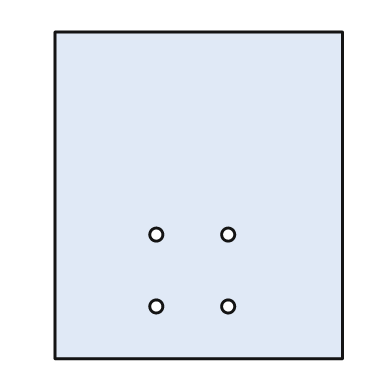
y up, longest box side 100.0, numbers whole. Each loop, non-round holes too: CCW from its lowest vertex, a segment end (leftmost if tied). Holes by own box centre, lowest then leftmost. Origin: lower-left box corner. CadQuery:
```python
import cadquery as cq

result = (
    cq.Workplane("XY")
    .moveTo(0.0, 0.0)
    .lineTo(88.0, 0.0)
    .lineTo(88.0, 100.0)
    .lineTo(0.0, 100.0)
    .close()
    .moveTo(31.0, 16.0)
    .circle(2.0)
    .moveTo(53.0, 16.0)
    .circle(2.0)
    .moveTo(31.0, 38.0)
    .circle(2.0)
    .moveTo(53.0, 38.0)
    .circle(2.0)
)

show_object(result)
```